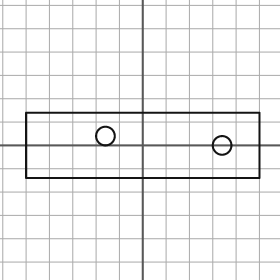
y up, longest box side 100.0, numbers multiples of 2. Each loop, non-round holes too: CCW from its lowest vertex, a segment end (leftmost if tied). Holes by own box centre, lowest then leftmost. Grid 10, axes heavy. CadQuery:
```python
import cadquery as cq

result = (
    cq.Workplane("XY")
    .moveTo(-50.0, -14.0)
    .lineTo(50.0, -14.0)
    .lineTo(50.0, 14.0)
    .lineTo(-50.0, 14.0)
    .close()
    .moveTo(34.0, 0.0)
    .circle(4.0)
    .moveTo(-16.0, 4.0)
    .circle(4.0)
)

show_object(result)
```